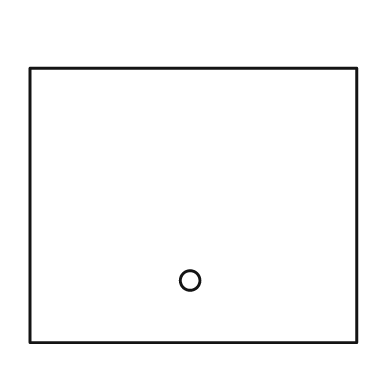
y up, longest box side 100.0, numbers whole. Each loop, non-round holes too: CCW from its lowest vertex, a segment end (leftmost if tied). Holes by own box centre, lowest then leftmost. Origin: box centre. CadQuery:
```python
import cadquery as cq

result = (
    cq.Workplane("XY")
    .moveTo(-50.0, -42.0)
    .lineTo(50.0, -42.0)
    .lineTo(50.0, 42.0)
    .lineTo(-50.0, 42.0)
    .close()
    .moveTo(-1.0, -23.0)
    .circle(3.0)
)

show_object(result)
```